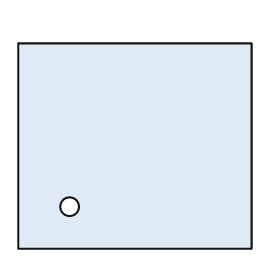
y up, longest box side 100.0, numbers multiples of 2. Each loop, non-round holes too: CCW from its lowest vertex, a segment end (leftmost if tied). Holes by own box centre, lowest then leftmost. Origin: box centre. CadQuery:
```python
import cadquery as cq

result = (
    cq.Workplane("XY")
    .moveTo(-50.0, -44.0)
    .lineTo(50.0, -44.0)
    .lineTo(50.0, 44.0)
    .lineTo(-50.0, 44.0)
    .close()
    .moveTo(-28.0, -26.0)
    .circle(4.0)
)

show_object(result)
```